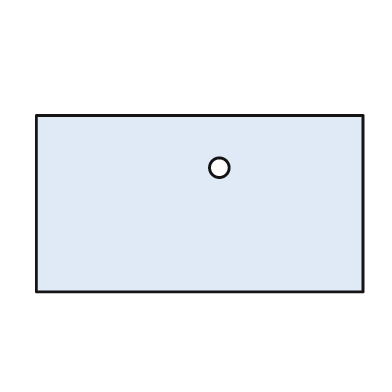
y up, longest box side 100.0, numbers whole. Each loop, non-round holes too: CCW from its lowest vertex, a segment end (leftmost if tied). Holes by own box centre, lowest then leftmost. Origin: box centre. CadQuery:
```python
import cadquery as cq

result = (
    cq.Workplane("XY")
    .moveTo(-50.0, -27.0)
    .lineTo(50.0, -27.0)
    .lineTo(50.0, 27.0)
    .lineTo(-50.0, 27.0)
    .close()
    .moveTo(6.0, 11.0)
    .circle(3.0)
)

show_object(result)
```